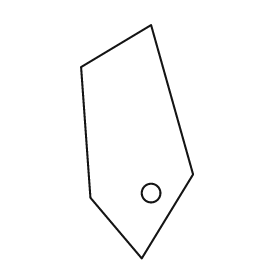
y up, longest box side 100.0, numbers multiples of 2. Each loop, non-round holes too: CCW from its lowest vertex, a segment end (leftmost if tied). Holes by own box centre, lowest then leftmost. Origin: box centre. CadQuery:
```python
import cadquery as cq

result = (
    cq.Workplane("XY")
    .moveTo(2.0, -50.0)
    .lineTo(24.0, -14.0)
    .lineTo(6.0, 50.0)
    .lineTo(-24.0, 32.0)
    .lineTo(-20.0, -24.0)
    .close()
    .moveTo(6.0, -22.0)
    .circle(4.0)
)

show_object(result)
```